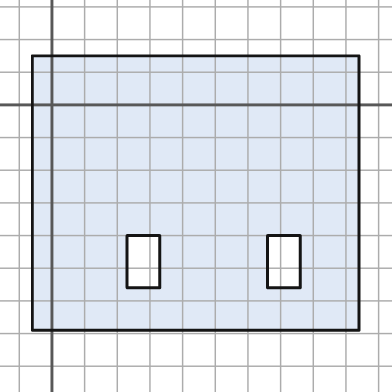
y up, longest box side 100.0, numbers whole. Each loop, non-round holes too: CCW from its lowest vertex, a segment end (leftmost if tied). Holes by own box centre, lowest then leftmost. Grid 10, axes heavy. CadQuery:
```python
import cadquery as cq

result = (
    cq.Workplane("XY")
    .moveTo(-6.0, -69.0)
    .lineTo(94.0, -69.0)
    .lineTo(94.0, 15.0)
    .lineTo(-6.0, 15.0)
    .close()
    .moveTo(23.0, -56.0)
    .lineTo(33.0, -56.0)
    .lineTo(33.0, -40.0)
    .lineTo(23.0, -40.0)
    .close()
    .moveTo(66.0, -56.0)
    .lineTo(76.0, -56.0)
    .lineTo(76.0, -40.0)
    .lineTo(66.0, -40.0)
    .close()
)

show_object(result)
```